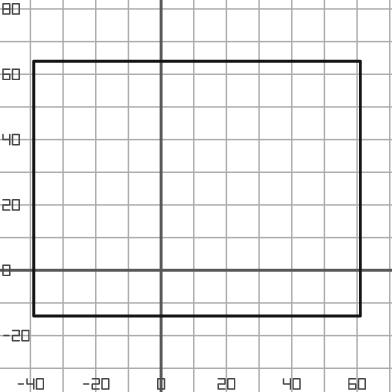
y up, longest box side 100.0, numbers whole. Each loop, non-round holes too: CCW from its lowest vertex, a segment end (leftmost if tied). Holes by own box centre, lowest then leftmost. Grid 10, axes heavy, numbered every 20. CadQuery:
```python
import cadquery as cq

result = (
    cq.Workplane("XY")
    .moveTo(-39.0, -14.0)
    .lineTo(61.0, -14.0)
    .lineTo(61.0, 64.0)
    .lineTo(-39.0, 64.0)
    .close()
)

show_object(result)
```